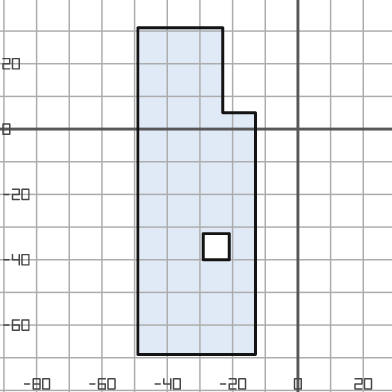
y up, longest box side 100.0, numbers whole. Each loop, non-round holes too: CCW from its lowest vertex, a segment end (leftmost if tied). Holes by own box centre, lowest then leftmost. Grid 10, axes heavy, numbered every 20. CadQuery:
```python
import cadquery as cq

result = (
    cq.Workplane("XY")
    .moveTo(-49.0, -69.0)
    .lineTo(-13.0, -69.0)
    .lineTo(-13.0, 5.0)
    .lineTo(-23.0, 5.0)
    .lineTo(-23.0, 31.0)
    .lineTo(-49.0, 31.0)
    .close()
    .moveTo(-29.0, -40.0)
    .lineTo(-21.0, -40.0)
    .lineTo(-21.0, -32.0)
    .lineTo(-29.0, -32.0)
    .close()
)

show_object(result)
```